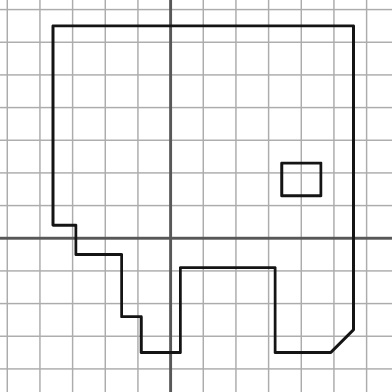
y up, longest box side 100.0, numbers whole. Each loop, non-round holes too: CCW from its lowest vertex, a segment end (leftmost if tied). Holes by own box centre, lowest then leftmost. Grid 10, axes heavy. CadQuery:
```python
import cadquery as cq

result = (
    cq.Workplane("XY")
    .moveTo(-9.0, -35.0)
    .lineTo(3.0, -35.0)
    .lineTo(3.0, -9.0)
    .lineTo(32.0, -9.0)
    .lineTo(32.0, -35.0)
    .lineTo(49.0, -35.0)
    .lineTo(56.0, -28.0)
    .lineTo(56.0, 65.0)
    .lineTo(-36.0, 65.0)
    .lineTo(-36.0, 4.0)
    .lineTo(-29.0, 4.0)
    .lineTo(-29.0, -5.0)
    .lineTo(-15.0, -5.0)
    .lineTo(-15.0, -24.0)
    .lineTo(-9.0, -24.0)
    .close()
    .moveTo(34.0, 13.0)
    .lineTo(46.0, 13.0)
    .lineTo(46.0, 23.0)
    .lineTo(34.0, 23.0)
    .close()
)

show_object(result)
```